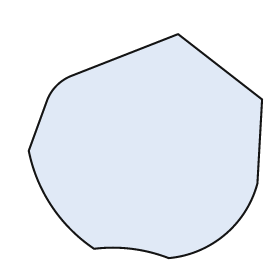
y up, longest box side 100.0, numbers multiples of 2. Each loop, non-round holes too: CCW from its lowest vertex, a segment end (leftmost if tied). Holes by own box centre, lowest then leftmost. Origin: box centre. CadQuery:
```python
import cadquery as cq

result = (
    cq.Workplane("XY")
    .moveTo(10.0, -48.0)
    .threePointArc((34.0, -38.0), (48.0, -16.0))
    .lineTo(50.0, 20.0)
    .lineTo(14.0, 48.0)
    .lineTo(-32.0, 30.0)
    .threePointArc((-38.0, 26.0), (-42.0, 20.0))
    .lineTo(-50.0, -2.0)
    .threePointArc((-40.0, -26.0), (-22.0, -44.0))
    .threePointArc((-6.0, -44.0), (10.0, -48.0))
    .close()
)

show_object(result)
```